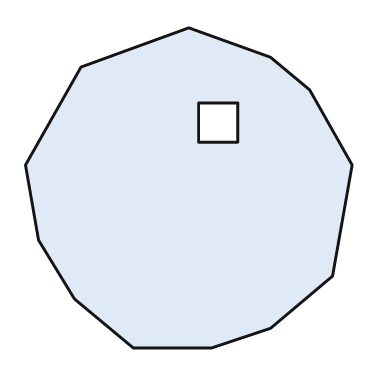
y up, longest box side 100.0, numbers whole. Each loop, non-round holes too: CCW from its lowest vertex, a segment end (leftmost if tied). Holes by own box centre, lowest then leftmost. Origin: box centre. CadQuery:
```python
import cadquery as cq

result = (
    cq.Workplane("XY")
    .moveTo(-17.0, -49.0)
    .lineTo(7.0, -49.0)
    .lineTo(25.0, -43.0)
    .lineTo(44.0, -27.0)
    .lineTo(50.0, 7.0)
    .lineTo(37.0, 30.0)
    .lineTo(25.0, 40.0)
    .lineTo(0.0, 49.0)
    .lineTo(-33.0, 37.0)
    .lineTo(-50.0, 7.0)
    .lineTo(-46.0, -16.0)
    .lineTo(-35.0, -34.0)
    .close()
    .moveTo(3.0, 14.0)
    .lineTo(15.0, 14.0)
    .lineTo(15.0, 26.0)
    .lineTo(3.0, 26.0)
    .close()
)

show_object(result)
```